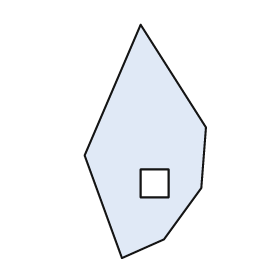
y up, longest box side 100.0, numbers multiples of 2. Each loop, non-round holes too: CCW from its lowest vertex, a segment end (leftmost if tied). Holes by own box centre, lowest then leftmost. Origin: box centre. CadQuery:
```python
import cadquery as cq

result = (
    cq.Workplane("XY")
    .moveTo(-10.0, -50.0)
    .lineTo(8.0, -42.0)
    .lineTo(24.0, -20.0)
    .lineTo(26.0, 6.0)
    .lineTo(-2.0, 50.0)
    .lineTo(-26.0, -6.0)
    .close()
    .moveTo(-2.0, -24.0)
    .lineTo(10.0, -24.0)
    .lineTo(10.0, -12.0)
    .lineTo(-2.0, -12.0)
    .close()
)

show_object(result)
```